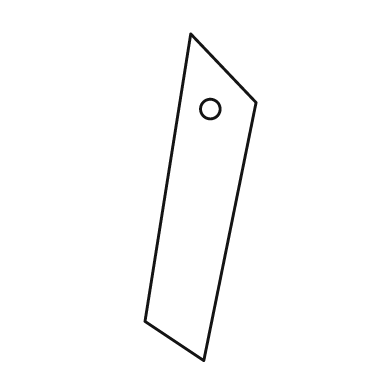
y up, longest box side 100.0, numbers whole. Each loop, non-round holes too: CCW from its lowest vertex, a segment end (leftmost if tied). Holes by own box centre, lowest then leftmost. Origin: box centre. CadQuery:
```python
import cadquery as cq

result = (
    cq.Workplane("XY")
    .moveTo(1.0, -50.0)
    .lineTo(17.0, 29.0)
    .lineTo(-3.0, 50.0)
    .lineTo(-17.0, -38.0)
    .close()
    .moveTo(3.0, 27.0)
    .circle(3.0)
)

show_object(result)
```